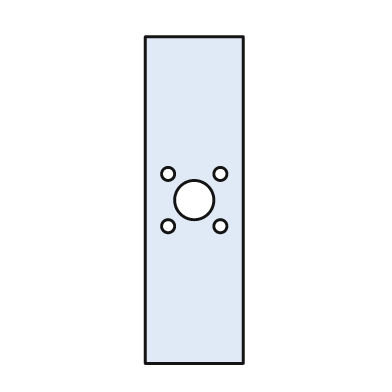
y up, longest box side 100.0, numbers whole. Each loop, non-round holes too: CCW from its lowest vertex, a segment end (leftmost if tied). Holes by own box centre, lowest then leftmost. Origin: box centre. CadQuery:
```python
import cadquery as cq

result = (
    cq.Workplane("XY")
    .moveTo(-15.0, -50.0)
    .lineTo(15.0, -50.0)
    .lineTo(15.0, 50.0)
    .lineTo(-15.0, 50.0)
    .close()
    .moveTo(-8.0, -8.0)
    .circle(2.0)
    .moveTo(8.0, -8.0)
    .circle(2.0)
    .moveTo(0.0, 0.0)
    .circle(6.0)
    .moveTo(-8.0, 8.0)
    .circle(2.0)
    .moveTo(8.0, 8.0)
    .circle(2.0)
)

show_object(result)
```